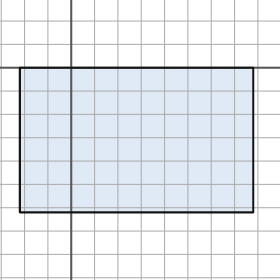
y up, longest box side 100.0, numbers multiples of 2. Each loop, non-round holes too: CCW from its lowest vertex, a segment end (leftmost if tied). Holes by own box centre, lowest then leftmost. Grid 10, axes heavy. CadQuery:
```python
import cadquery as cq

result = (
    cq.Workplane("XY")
    .moveTo(-22.0, -62.0)
    .lineTo(78.0, -62.0)
    .lineTo(78.0, 0.0)
    .lineTo(-22.0, 0.0)
    .close()
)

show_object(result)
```